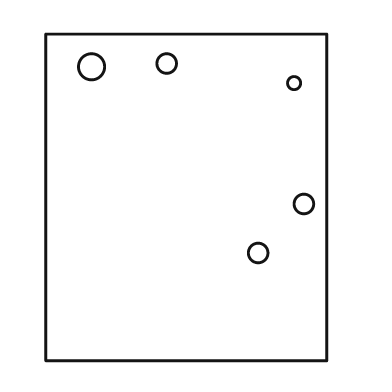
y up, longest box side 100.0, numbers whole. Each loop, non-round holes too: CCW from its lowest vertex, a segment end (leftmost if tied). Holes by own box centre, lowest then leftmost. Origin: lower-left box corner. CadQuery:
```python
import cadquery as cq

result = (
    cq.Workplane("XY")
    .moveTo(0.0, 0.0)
    .lineTo(86.0, 0.0)
    .lineTo(86.0, 100.0)
    .lineTo(0.0, 100.0)
    .close()
    .moveTo(65.0, 33.0)
    .circle(3.0)
    .moveTo(79.0, 48.0)
    .circle(3.0)
    .moveTo(76.0, 85.0)
    .circle(2.0)
    .moveTo(14.0, 90.0)
    .circle(4.0)
    .moveTo(37.0, 91.0)
    .circle(3.0)
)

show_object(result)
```